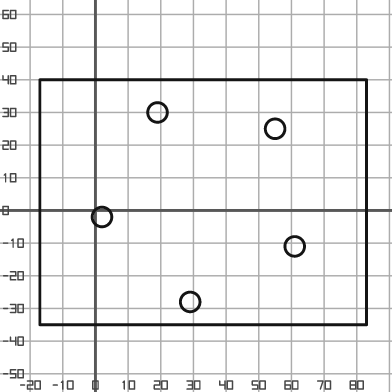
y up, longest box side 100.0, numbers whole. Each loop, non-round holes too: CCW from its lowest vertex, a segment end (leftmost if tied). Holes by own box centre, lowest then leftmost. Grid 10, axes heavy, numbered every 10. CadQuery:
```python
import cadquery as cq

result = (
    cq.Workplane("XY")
    .moveTo(-17.0, -35.0)
    .lineTo(83.0, -35.0)
    .lineTo(83.0, 40.0)
    .lineTo(-17.0, 40.0)
    .close()
    .moveTo(29.0, -28.0)
    .circle(3.0)
    .moveTo(61.0, -11.0)
    .circle(3.0)
    .moveTo(2.0, -2.0)
    .circle(3.0)
    .moveTo(55.0, 25.0)
    .circle(3.0)
    .moveTo(19.0, 30.0)
    .circle(3.0)
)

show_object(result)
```